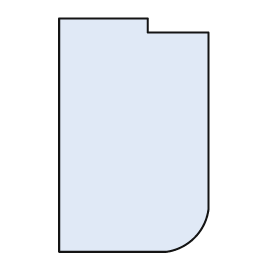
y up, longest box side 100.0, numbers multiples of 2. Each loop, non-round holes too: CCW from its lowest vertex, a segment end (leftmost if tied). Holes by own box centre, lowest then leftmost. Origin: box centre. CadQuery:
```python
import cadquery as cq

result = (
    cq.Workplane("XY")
    .moveTo(-32.0, -50.0)
    .lineTo(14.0, -50.0)
    .threePointArc((26.0, -44.0), (32.0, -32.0))
    .lineTo(32.0, 44.0)
    .lineTo(6.0, 44.0)
    .lineTo(6.0, 50.0)
    .lineTo(-32.0, 50.0)
    .close()
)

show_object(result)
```